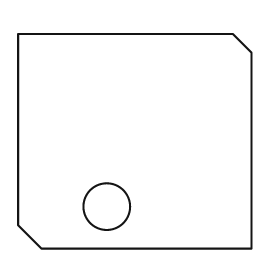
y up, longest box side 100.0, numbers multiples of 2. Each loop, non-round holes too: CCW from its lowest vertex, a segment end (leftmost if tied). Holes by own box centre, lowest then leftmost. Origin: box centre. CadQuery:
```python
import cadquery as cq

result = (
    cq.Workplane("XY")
    .moveTo(-40.0, -46.0)
    .lineTo(50.0, -46.0)
    .lineTo(50.0, 38.0)
    .lineTo(42.0, 46.0)
    .lineTo(-50.0, 46.0)
    .lineTo(-50.0, -36.0)
    .close()
    .moveTo(-12.0, -28.0)
    .circle(10.0)
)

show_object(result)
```